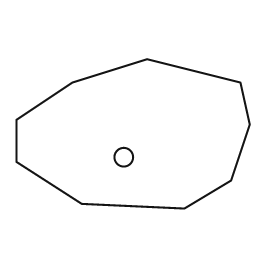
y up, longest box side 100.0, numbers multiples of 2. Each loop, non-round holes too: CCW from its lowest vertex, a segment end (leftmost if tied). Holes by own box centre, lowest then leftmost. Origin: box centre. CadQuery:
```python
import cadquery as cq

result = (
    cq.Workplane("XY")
    .moveTo(22.0, -32.0)
    .lineTo(42.0, -20.0)
    .lineTo(50.0, 4.0)
    .lineTo(46.0, 22.0)
    .lineTo(6.0, 32.0)
    .lineTo(-26.0, 22.0)
    .lineTo(-50.0, 6.0)
    .lineTo(-50.0, -12.0)
    .lineTo(-22.0, -30.0)
    .close()
    .moveTo(-4.0, -10.0)
    .circle(4.0)
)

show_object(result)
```